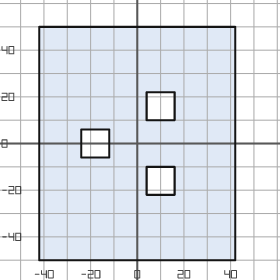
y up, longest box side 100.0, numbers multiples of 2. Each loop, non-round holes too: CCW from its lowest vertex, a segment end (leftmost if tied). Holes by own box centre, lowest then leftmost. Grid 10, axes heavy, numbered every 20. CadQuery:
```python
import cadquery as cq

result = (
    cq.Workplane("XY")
    .moveTo(-42.0, -50.0)
    .lineTo(42.0, -50.0)
    .lineTo(42.0, 50.0)
    .lineTo(-42.0, 50.0)
    .close()
    .moveTo(4.0, -22.0)
    .lineTo(16.0, -22.0)
    .lineTo(16.0, -10.0)
    .lineTo(4.0, -10.0)
    .close()
    .moveTo(-24.0, -6.0)
    .lineTo(-12.0, -6.0)
    .lineTo(-12.0, 6.0)
    .lineTo(-24.0, 6.0)
    .close()
    .moveTo(4.0, 10.0)
    .lineTo(16.0, 10.0)
    .lineTo(16.0, 22.0)
    .lineTo(4.0, 22.0)
    .close()
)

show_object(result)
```